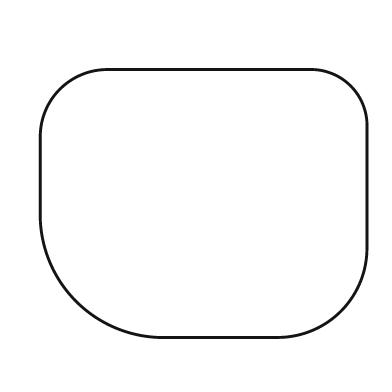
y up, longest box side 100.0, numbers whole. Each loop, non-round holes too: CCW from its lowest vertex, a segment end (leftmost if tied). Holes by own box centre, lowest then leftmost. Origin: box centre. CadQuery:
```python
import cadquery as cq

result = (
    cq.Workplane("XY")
    .moveTo(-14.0, -41.0)
    .lineTo(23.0, -41.0)
    .threePointArc((42.0, -33.0), (50.0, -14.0))
    .lineTo(50.0, 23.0)
    .threePointArc((45.0, 36.0), (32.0, 41.0))
    .lineTo(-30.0, 41.0)
    .threePointArc((-44.0, 35.0), (-50.0, 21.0))
    .lineTo(-50.0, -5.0)
    .threePointArc((-39.0, -30.0), (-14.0, -41.0))
    .close()
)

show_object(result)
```